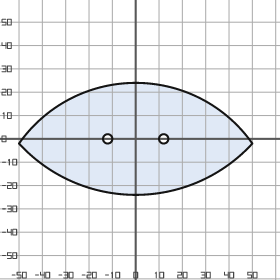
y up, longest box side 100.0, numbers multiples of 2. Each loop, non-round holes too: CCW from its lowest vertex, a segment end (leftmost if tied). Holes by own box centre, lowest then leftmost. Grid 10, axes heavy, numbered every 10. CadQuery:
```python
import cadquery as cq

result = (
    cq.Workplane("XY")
    .moveTo(-50.0, -2.0)
    .threePointArc((0.0, -24.0), (50.0, -2.0))
    .threePointArc((0.0, 24.0), (-50.0, -2.0))
    .close()
    .moveTo(-12.0, 0.0)
    .circle(2.0)
    .moveTo(12.0, 0.0)
    .circle(2.0)
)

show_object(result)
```